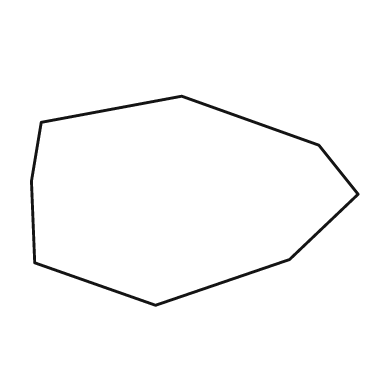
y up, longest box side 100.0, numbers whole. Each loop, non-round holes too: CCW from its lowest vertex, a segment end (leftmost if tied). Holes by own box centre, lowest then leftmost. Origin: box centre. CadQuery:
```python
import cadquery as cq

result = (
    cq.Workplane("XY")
    .moveTo(-12.0, -32.0)
    .lineTo(29.0, -18.0)
    .lineTo(50.0, 2.0)
    .lineTo(38.0, 17.0)
    .lineTo(-4.0, 32.0)
    .lineTo(-47.0, 24.0)
    .lineTo(-50.0, 6.0)
    .lineTo(-49.0, -19.0)
    .close()
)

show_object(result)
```